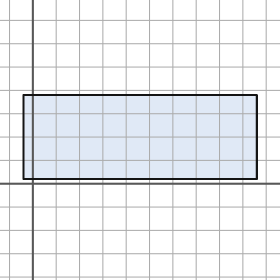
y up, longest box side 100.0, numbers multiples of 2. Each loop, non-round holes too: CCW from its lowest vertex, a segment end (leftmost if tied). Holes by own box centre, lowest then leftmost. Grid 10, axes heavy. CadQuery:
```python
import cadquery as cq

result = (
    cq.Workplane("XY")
    .moveTo(-4.0, 2.0)
    .lineTo(96.0, 2.0)
    .lineTo(96.0, 38.0)
    .lineTo(-4.0, 38.0)
    .close()
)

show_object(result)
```